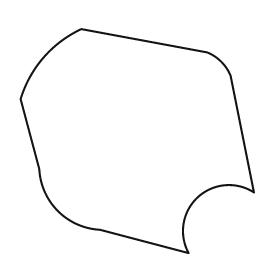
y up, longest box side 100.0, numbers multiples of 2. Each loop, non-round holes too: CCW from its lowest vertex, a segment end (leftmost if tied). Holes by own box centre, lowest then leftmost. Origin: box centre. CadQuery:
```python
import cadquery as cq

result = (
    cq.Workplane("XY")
    .moveTo(22.0, -48.0)
    .threePointArc((26.0, -24.0), (50.0, -22.0))
    .lineTo(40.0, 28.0)
    .threePointArc((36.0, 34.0), (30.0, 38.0))
    .lineTo(-24.0, 48.0)
    .threePointArc((-40.0, 36.0), (-50.0, 18.0))
    .lineTo(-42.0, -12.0)
    .threePointArc((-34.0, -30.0), (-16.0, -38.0))
    .close()
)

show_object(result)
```